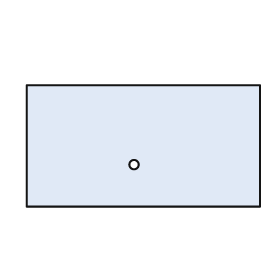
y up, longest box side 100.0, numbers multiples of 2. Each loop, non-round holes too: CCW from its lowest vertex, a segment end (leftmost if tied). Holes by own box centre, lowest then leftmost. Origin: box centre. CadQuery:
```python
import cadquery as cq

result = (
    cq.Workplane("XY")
    .moveTo(-50.0, -26.0)
    .lineTo(50.0, -26.0)
    .lineTo(50.0, 26.0)
    .lineTo(-50.0, 26.0)
    .close()
    .moveTo(-4.0, -8.0)
    .circle(2.0)
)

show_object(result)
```